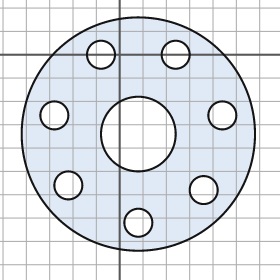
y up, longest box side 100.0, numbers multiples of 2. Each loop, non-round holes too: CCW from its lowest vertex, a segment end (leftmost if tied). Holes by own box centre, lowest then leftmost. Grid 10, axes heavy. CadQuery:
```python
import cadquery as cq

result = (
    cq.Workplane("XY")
    .moveTo(8.0, -34.0)
    .circle(50.0)
    .moveTo(8.0, -72.0)
    .circle(6.0)
    .moveTo(36.0, -58.0)
    .circle(6.0)
    .moveTo(-22.0, -56.0)
    .circle(6.0)
    .moveTo(8.0, -34.0)
    .circle(16.0)
    .moveTo(-28.0, -26.0)
    .circle(6.0)
    .moveTo(44.0, -26.0)
    .circle(6.0)
    .moveTo(-8.0, 0.0)
    .circle(6.0)
    .moveTo(24.0, 0.0)
    .circle(6.0)
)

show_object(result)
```